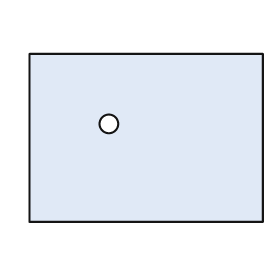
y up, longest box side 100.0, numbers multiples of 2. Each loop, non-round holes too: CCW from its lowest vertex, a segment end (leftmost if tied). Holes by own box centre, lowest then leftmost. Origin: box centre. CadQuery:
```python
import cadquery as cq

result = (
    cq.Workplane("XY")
    .moveTo(-50.0, -36.0)
    .lineTo(50.0, -36.0)
    .lineTo(50.0, 36.0)
    .lineTo(-50.0, 36.0)
    .close()
    .moveTo(-16.0, 6.0)
    .circle(4.0)
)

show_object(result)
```